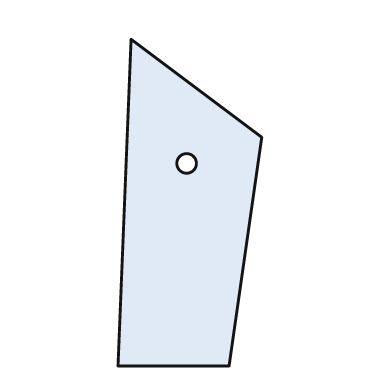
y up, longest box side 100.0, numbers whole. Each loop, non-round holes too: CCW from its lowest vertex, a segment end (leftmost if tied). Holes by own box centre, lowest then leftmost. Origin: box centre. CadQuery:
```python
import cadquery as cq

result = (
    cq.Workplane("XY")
    .moveTo(-22.0, -50.0)
    .lineTo(12.0, -50.0)
    .lineTo(22.0, 20.0)
    .lineTo(-18.0, 50.0)
    .close()
    .moveTo(-1.0, 12.0)
    .circle(3.0)
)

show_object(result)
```